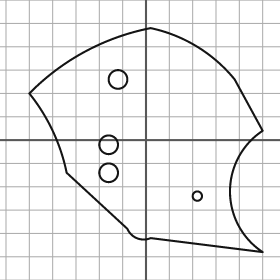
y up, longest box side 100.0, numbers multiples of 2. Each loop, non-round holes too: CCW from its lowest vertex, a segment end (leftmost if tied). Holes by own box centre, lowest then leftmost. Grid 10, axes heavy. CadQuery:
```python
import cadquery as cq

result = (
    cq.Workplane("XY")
    .moveTo(50.0, -48.0)
    .threePointArc((36.0, -22.0), (50.0, 4.0))
    .lineTo(38.0, 26.0)
    .threePointArc((22.0, 40.0), (2.0, 48.0))
    .threePointArc((-26.0, 38.0), (-50.0, 20.0))
    .threePointArc((-40.0, 4.0), (-34.0, -14.0))
    .lineTo(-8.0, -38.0)
    .threePointArc((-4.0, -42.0), (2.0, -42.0))
    .close()
    .moveTo(22.0, -24.0)
    .circle(2.0)
    .moveTo(-16.0, -14.0)
    .circle(4.0)
    .moveTo(-16.0, -2.0)
    .circle(4.0)
    .moveTo(-12.0, 26.0)
    .circle(4.0)
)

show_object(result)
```